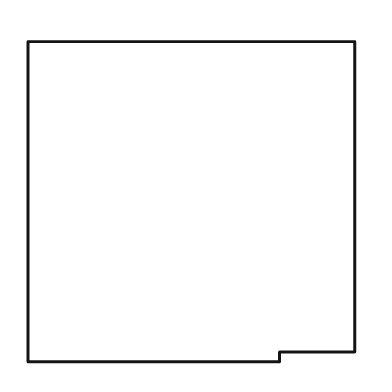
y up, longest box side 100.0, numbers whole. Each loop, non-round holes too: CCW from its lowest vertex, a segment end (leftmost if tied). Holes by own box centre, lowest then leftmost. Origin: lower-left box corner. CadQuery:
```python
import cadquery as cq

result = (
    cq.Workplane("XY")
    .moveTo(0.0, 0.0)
    .lineTo(77.0, 0.0)
    .lineTo(77.0, 3.0)
    .lineTo(100.0, 3.0)
    .lineTo(100.0, 98.0)
    .lineTo(0.0, 98.0)
    .close()
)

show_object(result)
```